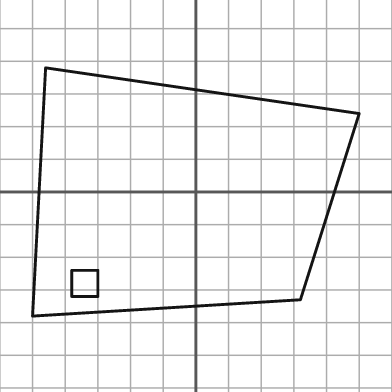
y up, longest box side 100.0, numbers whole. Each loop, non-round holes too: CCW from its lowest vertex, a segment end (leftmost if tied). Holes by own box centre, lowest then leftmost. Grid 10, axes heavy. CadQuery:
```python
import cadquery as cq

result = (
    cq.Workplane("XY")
    .moveTo(-50.0, -38.0)
    .lineTo(32.0, -33.0)
    .lineTo(50.0, 24.0)
    .lineTo(-46.0, 38.0)
    .close()
    .moveTo(-38.0, -32.0)
    .lineTo(-30.0, -32.0)
    .lineTo(-30.0, -24.0)
    .lineTo(-38.0, -24.0)
    .close()
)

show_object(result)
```